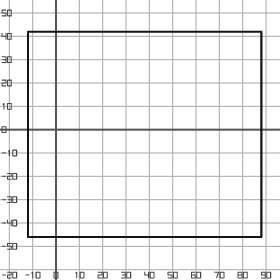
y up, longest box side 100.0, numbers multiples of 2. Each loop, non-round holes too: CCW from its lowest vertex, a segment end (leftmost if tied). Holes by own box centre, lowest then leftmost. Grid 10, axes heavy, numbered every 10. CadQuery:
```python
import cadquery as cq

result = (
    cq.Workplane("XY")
    .moveTo(-12.0, -46.0)
    .lineTo(88.0, -46.0)
    .lineTo(88.0, 42.0)
    .lineTo(-12.0, 42.0)
    .close()
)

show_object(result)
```